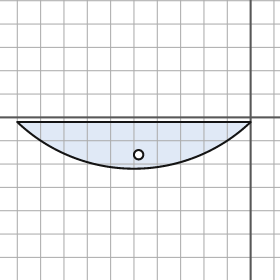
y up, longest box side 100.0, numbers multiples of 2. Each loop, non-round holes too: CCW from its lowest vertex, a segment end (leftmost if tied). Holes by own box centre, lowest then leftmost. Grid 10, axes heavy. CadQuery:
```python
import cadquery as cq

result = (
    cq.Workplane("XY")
    .moveTo(-100.0, -2.0)
    .threePointArc((-50.0, -22.0), (0.0, -2.0))
    .close()
    .moveTo(-48.0, -16.0)
    .circle(2.0)
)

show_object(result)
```